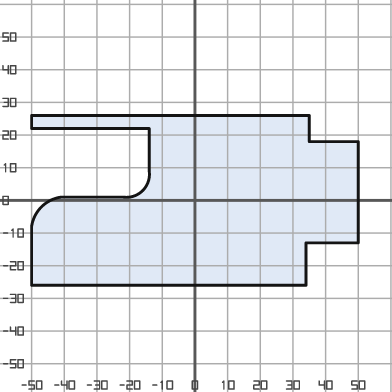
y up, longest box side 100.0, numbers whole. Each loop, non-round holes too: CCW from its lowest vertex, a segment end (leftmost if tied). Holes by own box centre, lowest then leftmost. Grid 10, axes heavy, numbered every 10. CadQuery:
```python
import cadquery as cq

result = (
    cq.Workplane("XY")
    .moveTo(-50.0, -26.0)
    .lineTo(34.0, -26.0)
    .lineTo(34.0, -13.0)
    .lineTo(50.0, -13.0)
    .lineTo(50.0, 18.0)
    .lineTo(35.0, 18.0)
    .lineTo(35.0, 26.0)
    .lineTo(-50.0, 26.0)
    .lineTo(-50.0, 22.0)
    .lineTo(-14.0, 22.0)
    .lineTo(-14.0, 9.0)
    .threePointArc((-16.0, 3.0), (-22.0, 1.0))
    .lineTo(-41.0, 1.0)
    .threePointArc((-47.0, -2.0), (-50.0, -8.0))
    .close()
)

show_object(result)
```